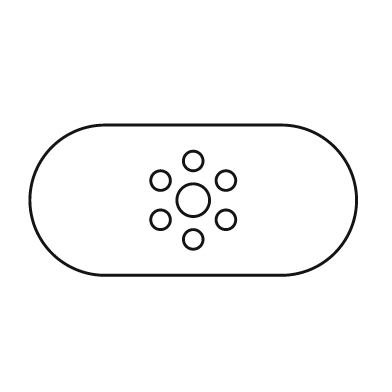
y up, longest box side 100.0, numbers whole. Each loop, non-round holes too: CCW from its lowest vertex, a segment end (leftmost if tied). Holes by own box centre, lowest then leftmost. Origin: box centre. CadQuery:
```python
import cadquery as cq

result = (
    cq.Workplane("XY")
    .moveTo(-27.0, -23.0)
    .lineTo(27.0, -23.0)
    .threePointArc((50.0, 0.0), (27.0, 23.0))
    .lineTo(-27.0, 23.0)
    .threePointArc((-50.0, 0.0), (-27.0, -23.0))
    .close()
    .moveTo(0.0, -12.0)
    .circle(3.0)
    .moveTo(-10.0, -6.0)
    .circle(3.0)
    .moveTo(10.0, -6.0)
    .circle(3.0)
    .moveTo(0.0, 0.0)
    .circle(5.0)
    .moveTo(-10.0, 6.0)
    .circle(3.0)
    .moveTo(10.0, 6.0)
    .circle(3.0)
    .moveTo(0.0, 12.0)
    .circle(3.0)
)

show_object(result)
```